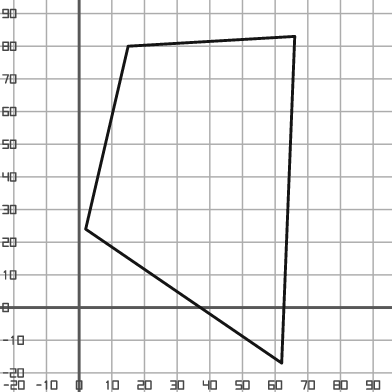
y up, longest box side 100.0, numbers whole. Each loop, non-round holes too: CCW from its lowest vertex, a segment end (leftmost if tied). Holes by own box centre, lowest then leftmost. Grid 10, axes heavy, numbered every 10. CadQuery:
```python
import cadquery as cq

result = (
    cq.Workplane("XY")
    .moveTo(62.0, -17.0)
    .lineTo(66.0, 83.0)
    .lineTo(15.0, 80.0)
    .lineTo(2.0, 24.0)
    .close()
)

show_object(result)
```